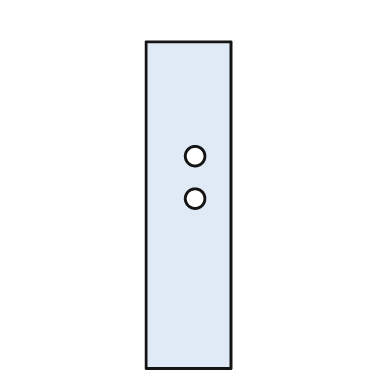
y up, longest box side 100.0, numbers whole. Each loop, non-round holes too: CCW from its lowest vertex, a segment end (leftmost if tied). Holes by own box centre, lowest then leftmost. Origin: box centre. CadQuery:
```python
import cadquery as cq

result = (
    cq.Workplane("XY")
    .moveTo(-13.0, -50.0)
    .lineTo(13.0, -50.0)
    .lineTo(13.0, 50.0)
    .lineTo(-13.0, 50.0)
    .close()
    .moveTo(2.0, 2.0)
    .circle(3.0)
    .moveTo(2.0, 15.0)
    .circle(3.0)
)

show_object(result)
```